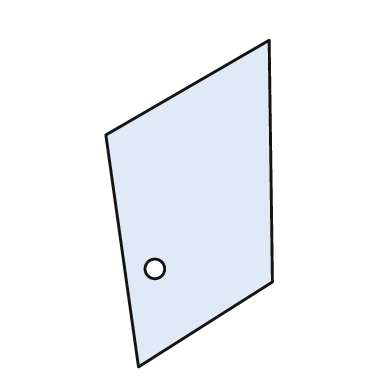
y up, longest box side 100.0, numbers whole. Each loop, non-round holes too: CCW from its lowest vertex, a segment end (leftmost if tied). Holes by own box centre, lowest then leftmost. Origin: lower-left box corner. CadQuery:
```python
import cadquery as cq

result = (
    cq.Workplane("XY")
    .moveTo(10.0, 0.0)
    .lineTo(51.0, 26.0)
    .lineTo(50.0, 100.0)
    .lineTo(0.0, 71.0)
    .close()
    .moveTo(15.0, 30.0)
    .circle(3.0)
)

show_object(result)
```